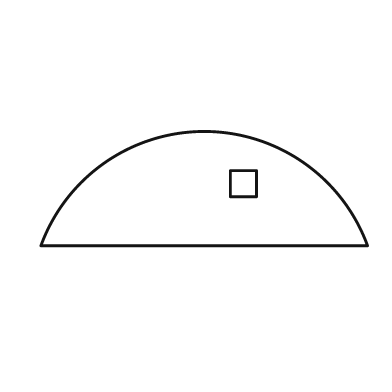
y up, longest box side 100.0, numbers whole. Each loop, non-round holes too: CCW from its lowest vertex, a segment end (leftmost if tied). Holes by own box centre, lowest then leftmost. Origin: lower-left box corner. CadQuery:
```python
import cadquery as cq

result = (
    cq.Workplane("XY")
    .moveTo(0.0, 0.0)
    .lineTo(100.0, 0.0)
    .threePointArc((50.0, 35.0), (0.0, 0.0))
    .close()
    .moveTo(58.0, 15.0)
    .lineTo(66.0, 15.0)
    .lineTo(66.0, 23.0)
    .lineTo(58.0, 23.0)
    .close()
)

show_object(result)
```